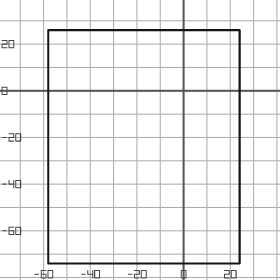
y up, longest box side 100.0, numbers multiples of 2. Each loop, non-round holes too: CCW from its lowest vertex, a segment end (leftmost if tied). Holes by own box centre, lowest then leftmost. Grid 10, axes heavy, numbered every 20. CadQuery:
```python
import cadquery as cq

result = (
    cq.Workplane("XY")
    .moveTo(-58.0, -74.0)
    .lineTo(24.0, -74.0)
    .lineTo(24.0, 26.0)
    .lineTo(-58.0, 26.0)
    .close()
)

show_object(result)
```